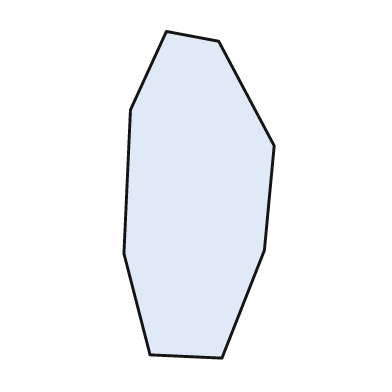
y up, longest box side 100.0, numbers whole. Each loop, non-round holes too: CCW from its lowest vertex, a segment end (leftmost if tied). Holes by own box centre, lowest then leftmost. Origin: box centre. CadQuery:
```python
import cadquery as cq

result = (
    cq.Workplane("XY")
    .moveTo(7.0, -50.0)
    .lineTo(20.0, -17.0)
    .lineTo(23.0, 15.0)
    .lineTo(6.0, 47.0)
    .lineTo(-10.0, 50.0)
    .lineTo(-21.0, 26.0)
    .lineTo(-23.0, -18.0)
    .lineTo(-15.0, -49.0)
    .close()
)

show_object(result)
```